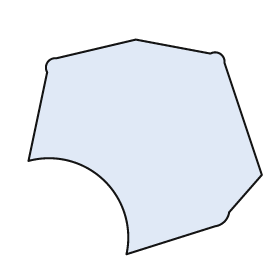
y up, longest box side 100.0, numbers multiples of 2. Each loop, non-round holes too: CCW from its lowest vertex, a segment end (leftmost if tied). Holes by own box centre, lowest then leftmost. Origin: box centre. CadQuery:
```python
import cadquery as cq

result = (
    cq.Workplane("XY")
    .moveTo(-8.0, -46.0)
    .lineTo(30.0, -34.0)
    .threePointArc((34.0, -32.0), (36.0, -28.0))
    .lineTo(50.0, -12.0)
    .lineTo(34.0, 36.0)
    .threePointArc((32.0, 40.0), (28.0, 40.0))
    .lineTo(-4.0, 46.0)
    .lineTo(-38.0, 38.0)
    .threePointArc((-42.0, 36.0), (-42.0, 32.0))
    .lineTo(-50.0, -6.0)
    .threePointArc((-18.0, -14.0), (-8.0, -46.0))
    .close()
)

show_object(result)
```